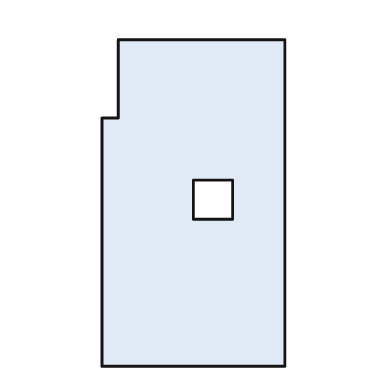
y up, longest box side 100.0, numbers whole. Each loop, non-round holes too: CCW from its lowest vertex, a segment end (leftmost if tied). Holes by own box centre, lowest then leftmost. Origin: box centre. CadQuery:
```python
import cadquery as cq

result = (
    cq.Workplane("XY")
    .moveTo(-28.0, -50.0)
    .lineTo(28.0, -50.0)
    .lineTo(28.0, 50.0)
    .lineTo(-23.0, 50.0)
    .lineTo(-23.0, 26.0)
    .lineTo(-28.0, 26.0)
    .close()
    .moveTo(0.0, -5.0)
    .lineTo(12.0, -5.0)
    .lineTo(12.0, 7.0)
    .lineTo(0.0, 7.0)
    .close()
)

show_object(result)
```